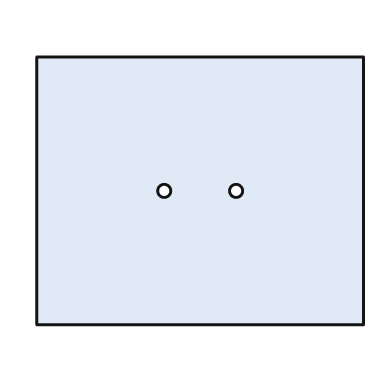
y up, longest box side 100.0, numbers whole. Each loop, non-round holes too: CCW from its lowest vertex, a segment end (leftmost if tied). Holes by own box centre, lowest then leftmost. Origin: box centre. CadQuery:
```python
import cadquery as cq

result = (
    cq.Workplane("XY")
    .moveTo(-50.0, -41.0)
    .lineTo(50.0, -41.0)
    .lineTo(50.0, 41.0)
    .lineTo(-50.0, 41.0)
    .close()
    .moveTo(-11.0, 0.0)
    .circle(2.0)
    .moveTo(11.0, 0.0)
    .circle(2.0)
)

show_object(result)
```